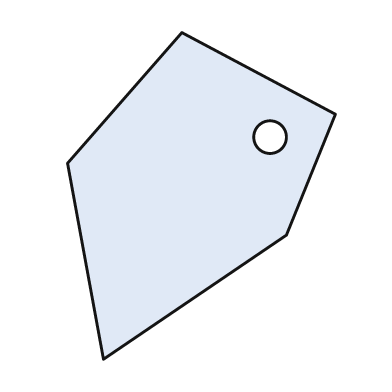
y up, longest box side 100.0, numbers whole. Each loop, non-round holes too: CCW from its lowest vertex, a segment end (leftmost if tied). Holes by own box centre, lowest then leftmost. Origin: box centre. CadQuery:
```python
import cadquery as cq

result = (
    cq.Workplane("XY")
    .moveTo(-30.0, -50.0)
    .lineTo(26.0, -12.0)
    .lineTo(41.0, 25.0)
    .lineTo(-6.0, 50.0)
    .lineTo(-41.0, 10.0)
    .close()
    .moveTo(21.0, 18.0)
    .circle(5.0)
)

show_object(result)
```